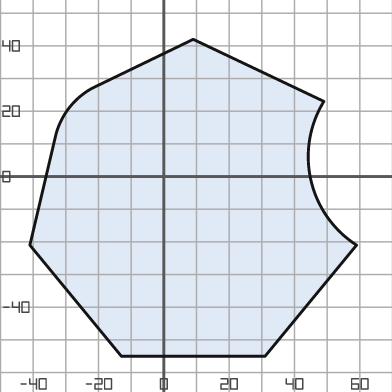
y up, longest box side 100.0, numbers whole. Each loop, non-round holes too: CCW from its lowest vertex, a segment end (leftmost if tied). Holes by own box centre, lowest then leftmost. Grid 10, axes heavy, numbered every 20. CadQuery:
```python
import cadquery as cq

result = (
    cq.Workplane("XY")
    .moveTo(-13.0, -55.0)
    .lineTo(31.0, -55.0)
    .lineTo(59.0, -21.0)
    .threePointArc((45.0, -1.0), (49.0, 23.0))
    .lineTo(9.0, 42.0)
    .lineTo(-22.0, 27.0)
    .threePointArc((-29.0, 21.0), (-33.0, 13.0))
    .lineTo(-41.0, -21.0)
    .close()
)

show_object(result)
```